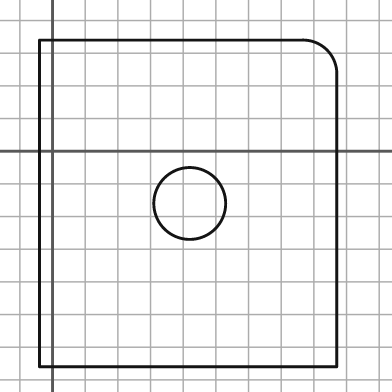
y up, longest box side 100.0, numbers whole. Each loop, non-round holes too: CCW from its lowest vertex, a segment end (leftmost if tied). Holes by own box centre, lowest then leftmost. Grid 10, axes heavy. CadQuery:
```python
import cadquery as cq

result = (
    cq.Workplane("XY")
    .moveTo(-4.0, -66.0)
    .lineTo(87.0, -66.0)
    .lineTo(87.0, 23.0)
    .threePointArc((84.0, 31.0), (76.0, 34.0))
    .lineTo(-4.0, 34.0)
    .close()
    .moveTo(42.0, -16.0)
    .circle(11.0)
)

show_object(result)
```